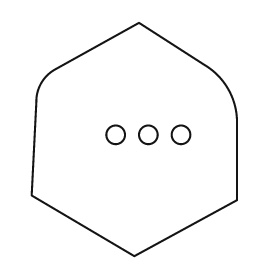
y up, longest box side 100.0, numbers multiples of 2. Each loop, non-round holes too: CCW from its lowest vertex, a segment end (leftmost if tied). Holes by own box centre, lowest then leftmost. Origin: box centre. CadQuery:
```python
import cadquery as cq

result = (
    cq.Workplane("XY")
    .moveTo(0.0, -50.0)
    .lineTo(44.0, -26.0)
    .lineTo(44.0, 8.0)
    .threePointArc((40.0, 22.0), (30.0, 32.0))
    .lineTo(2.0, 50.0)
    .lineTo(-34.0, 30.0)
    .threePointArc((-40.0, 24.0), (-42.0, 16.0))
    .lineTo(-44.0, -24.0)
    .close()
    .moveTo(-8.0, 2.0)
    .circle(4.0)
    .moveTo(6.0, 2.0)
    .circle(4.0)
    .moveTo(20.0, 2.0)
    .circle(4.0)
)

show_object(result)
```